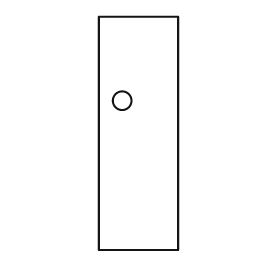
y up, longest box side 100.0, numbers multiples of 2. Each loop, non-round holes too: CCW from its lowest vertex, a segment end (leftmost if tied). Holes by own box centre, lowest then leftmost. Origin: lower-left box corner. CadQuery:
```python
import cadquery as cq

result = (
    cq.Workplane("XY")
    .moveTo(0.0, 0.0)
    .lineTo(34.0, 0.0)
    .lineTo(34.0, 100.0)
    .lineTo(0.0, 100.0)
    .close()
    .moveTo(10.0, 64.0)
    .circle(4.0)
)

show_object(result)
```